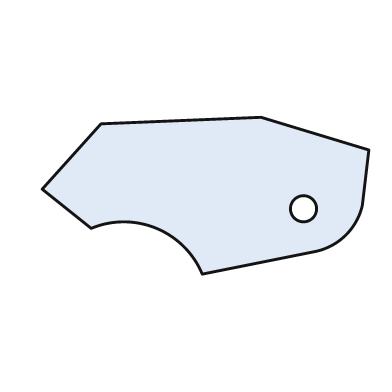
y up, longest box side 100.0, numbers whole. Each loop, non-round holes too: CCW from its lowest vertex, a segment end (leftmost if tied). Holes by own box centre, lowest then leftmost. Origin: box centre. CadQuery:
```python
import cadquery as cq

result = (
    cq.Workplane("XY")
    .moveTo(-1.0, -24.0)
    .lineTo(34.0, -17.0)
    .threePointArc((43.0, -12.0), (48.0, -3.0))
    .lineTo(50.0, 14.0)
    .lineTo(17.0, 24.0)
    .lineTo(-32.0, 22.0)
    .lineTo(-50.0, 2.0)
    .lineTo(-35.0, -10.0)
    .threePointArc((-15.0, -10.0), (-1.0, -24.0))
    .close()
    .moveTo(30.0, -4.0)
    .circle(4.0)
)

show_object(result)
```